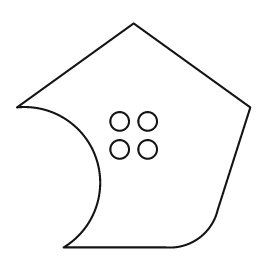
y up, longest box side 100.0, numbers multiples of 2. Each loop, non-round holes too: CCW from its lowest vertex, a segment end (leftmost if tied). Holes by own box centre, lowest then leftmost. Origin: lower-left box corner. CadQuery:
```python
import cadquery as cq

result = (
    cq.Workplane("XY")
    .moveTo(20.0, 0.0)
    .lineTo(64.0, 0.0)
    .threePointArc((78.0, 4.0), (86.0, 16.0))
    .lineTo(100.0, 60.0)
    .lineTo(50.0, 96.0)
    .lineTo(0.0, 60.0)
    .threePointArc((34.0, 38.0), (20.0, 0.0))
    .close()
    .moveTo(44.0, 42.0)
    .circle(4.0)
    .moveTo(56.0, 42.0)
    .circle(4.0)
    .moveTo(44.0, 54.0)
    .circle(4.0)
    .moveTo(56.0, 54.0)
    .circle(4.0)
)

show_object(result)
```